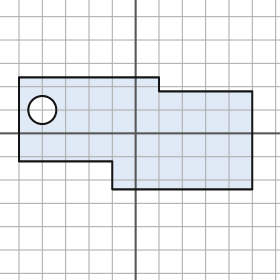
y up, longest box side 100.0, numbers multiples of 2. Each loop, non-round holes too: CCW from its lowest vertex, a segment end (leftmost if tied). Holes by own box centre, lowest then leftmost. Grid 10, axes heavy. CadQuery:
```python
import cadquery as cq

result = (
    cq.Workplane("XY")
    .moveTo(-10.0, -24.0)
    .lineTo(50.0, -24.0)
    .lineTo(50.0, 18.0)
    .lineTo(10.0, 18.0)
    .lineTo(10.0, 24.0)
    .lineTo(-50.0, 24.0)
    .lineTo(-50.0, -12.0)
    .lineTo(-10.0, -12.0)
    .close()
    .moveTo(-40.0, 10.0)
    .circle(6.0)
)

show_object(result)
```